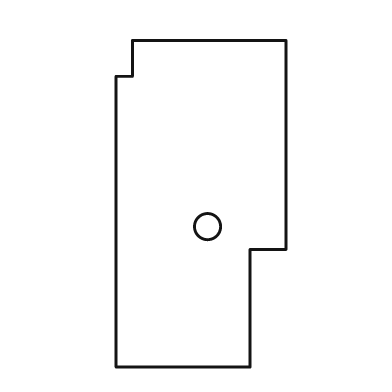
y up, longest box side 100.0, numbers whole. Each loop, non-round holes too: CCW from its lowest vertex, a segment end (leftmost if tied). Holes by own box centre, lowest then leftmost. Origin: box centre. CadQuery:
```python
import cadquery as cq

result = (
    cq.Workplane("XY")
    .moveTo(-26.0, -50.0)
    .lineTo(15.0, -50.0)
    .lineTo(15.0, -14.0)
    .lineTo(26.0, -14.0)
    .lineTo(26.0, 50.0)
    .lineTo(-21.0, 50.0)
    .lineTo(-21.0, 39.0)
    .lineTo(-26.0, 39.0)
    .close()
    .moveTo(2.0, -7.0)
    .circle(4.0)
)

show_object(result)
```